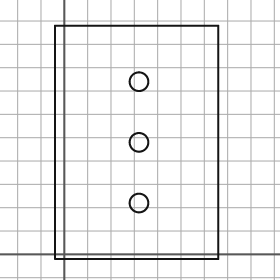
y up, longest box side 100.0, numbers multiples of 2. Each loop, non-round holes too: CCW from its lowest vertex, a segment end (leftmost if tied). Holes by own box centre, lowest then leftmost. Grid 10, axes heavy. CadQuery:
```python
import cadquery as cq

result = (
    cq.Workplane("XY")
    .moveTo(-4.0, -2.0)
    .lineTo(66.0, -2.0)
    .lineTo(66.0, 98.0)
    .lineTo(-4.0, 98.0)
    .close()
    .moveTo(32.0, 22.0)
    .circle(4.0)
    .moveTo(32.0, 48.0)
    .circle(4.0)
    .moveTo(32.0, 74.0)
    .circle(4.0)
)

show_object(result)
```